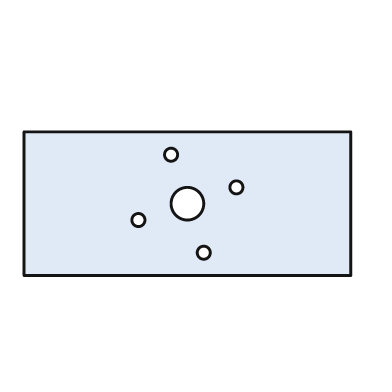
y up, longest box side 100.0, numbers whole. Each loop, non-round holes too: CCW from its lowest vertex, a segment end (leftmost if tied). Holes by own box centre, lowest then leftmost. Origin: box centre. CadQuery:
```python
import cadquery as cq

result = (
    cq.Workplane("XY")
    .moveTo(-50.0, -22.0)
    .lineTo(50.0, -22.0)
    .lineTo(50.0, 22.0)
    .lineTo(-50.0, 22.0)
    .close()
    .moveTo(5.0, -15.0)
    .circle(2.0)
    .moveTo(-15.0, -5.0)
    .circle(2.0)
    .moveTo(0.0, 0.0)
    .circle(5.0)
    .moveTo(15.0, 5.0)
    .circle(2.0)
    .moveTo(-5.0, 15.0)
    .circle(2.0)
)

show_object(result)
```